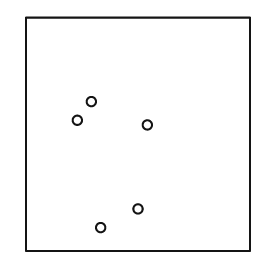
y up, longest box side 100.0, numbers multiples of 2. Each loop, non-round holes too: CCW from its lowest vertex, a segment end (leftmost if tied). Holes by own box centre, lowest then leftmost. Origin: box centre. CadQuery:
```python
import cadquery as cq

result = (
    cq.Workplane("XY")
    .moveTo(-48.0, -50.0)
    .lineTo(48.0, -50.0)
    .lineTo(48.0, 50.0)
    .lineTo(-48.0, 50.0)
    .close()
    .moveTo(-16.0, -40.0)
    .circle(2.0)
    .moveTo(0.0, -32.0)
    .circle(2.0)
    .moveTo(4.0, 4.0)
    .circle(2.0)
    .moveTo(-26.0, 6.0)
    .circle(2.0)
    .moveTo(-20.0, 14.0)
    .circle(2.0)
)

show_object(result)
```